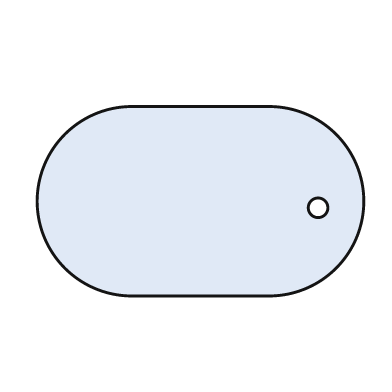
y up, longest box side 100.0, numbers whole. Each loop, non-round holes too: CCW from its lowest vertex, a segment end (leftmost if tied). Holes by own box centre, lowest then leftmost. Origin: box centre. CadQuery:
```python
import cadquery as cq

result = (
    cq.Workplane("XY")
    .moveTo(-21.0, -29.0)
    .lineTo(21.0, -29.0)
    .threePointArc((50.0, 0.0), (21.0, 29.0))
    .lineTo(-21.0, 29.0)
    .threePointArc((-50.0, 0.0), (-21.0, -29.0))
    .close()
    .moveTo(36.0, -2.0)
    .circle(3.0)
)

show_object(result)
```